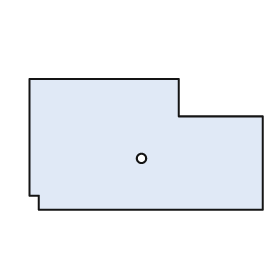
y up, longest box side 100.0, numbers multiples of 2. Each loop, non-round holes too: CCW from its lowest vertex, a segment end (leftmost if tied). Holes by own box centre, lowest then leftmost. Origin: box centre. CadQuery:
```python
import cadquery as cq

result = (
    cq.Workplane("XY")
    .moveTo(-46.0, -28.0)
    .lineTo(50.0, -28.0)
    .lineTo(50.0, 12.0)
    .lineTo(14.0, 12.0)
    .lineTo(14.0, 28.0)
    .lineTo(-50.0, 28.0)
    .lineTo(-50.0, -22.0)
    .lineTo(-46.0, -22.0)
    .close()
    .moveTo(-2.0, -6.0)
    .circle(2.0)
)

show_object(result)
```